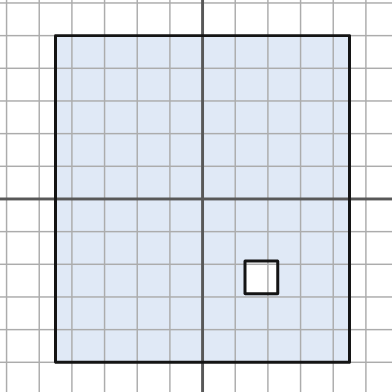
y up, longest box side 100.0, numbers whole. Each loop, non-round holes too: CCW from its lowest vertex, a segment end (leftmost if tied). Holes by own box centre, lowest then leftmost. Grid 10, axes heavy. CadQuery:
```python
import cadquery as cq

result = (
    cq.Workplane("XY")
    .moveTo(-45.0, -50.0)
    .lineTo(45.0, -50.0)
    .lineTo(45.0, 50.0)
    .lineTo(-45.0, 50.0)
    .close()
    .moveTo(13.0, -29.0)
    .lineTo(23.0, -29.0)
    .lineTo(23.0, -19.0)
    .lineTo(13.0, -19.0)
    .close()
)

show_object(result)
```